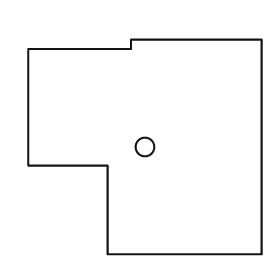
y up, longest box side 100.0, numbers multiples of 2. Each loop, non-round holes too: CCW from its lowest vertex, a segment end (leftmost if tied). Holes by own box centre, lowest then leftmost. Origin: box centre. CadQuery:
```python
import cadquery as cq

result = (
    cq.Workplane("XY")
    .moveTo(-16.0, -46.0)
    .lineTo(50.0, -46.0)
    .lineTo(50.0, 46.0)
    .lineTo(-6.0, 46.0)
    .lineTo(-6.0, 42.0)
    .lineTo(-50.0, 42.0)
    .lineTo(-50.0, -8.0)
    .lineTo(-16.0, -8.0)
    .close()
    .moveTo(0.0, 0.0)
    .circle(4.0)
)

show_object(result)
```